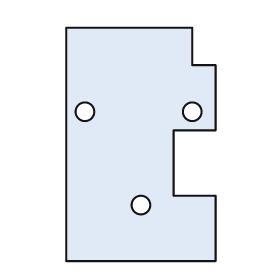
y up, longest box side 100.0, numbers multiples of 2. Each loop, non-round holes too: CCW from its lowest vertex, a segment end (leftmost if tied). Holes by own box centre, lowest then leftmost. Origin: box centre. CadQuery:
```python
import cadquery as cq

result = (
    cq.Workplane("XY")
    .moveTo(-32.0, -50.0)
    .lineTo(32.0, -50.0)
    .lineTo(32.0, -22.0)
    .lineTo(14.0, -22.0)
    .lineTo(14.0, 6.0)
    .lineTo(32.0, 6.0)
    .lineTo(32.0, 34.0)
    .lineTo(22.0, 34.0)
    .lineTo(22.0, 50.0)
    .lineTo(-32.0, 50.0)
    .close()
    .moveTo(0.0, -26.0)
    .circle(4.0)
    .moveTo(-24.0, 14.0)
    .circle(4.0)
    .moveTo(22.0, 14.0)
    .circle(4.0)
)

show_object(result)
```